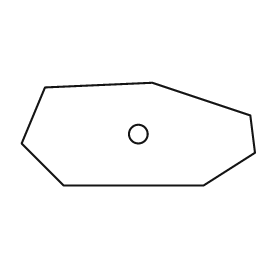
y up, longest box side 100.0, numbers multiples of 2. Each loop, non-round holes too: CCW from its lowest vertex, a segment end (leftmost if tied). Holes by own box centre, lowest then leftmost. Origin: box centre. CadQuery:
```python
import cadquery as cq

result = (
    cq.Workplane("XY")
    .moveTo(-32.0, -22.0)
    .lineTo(28.0, -22.0)
    .lineTo(50.0, -8.0)
    .lineTo(48.0, 8.0)
    .lineTo(6.0, 22.0)
    .lineTo(-40.0, 20.0)
    .lineTo(-50.0, -4.0)
    .close()
    .moveTo(0.0, 0.0)
    .circle(4.0)
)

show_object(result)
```